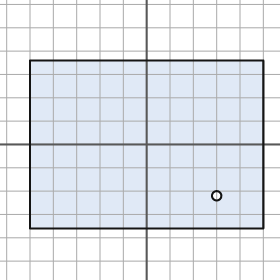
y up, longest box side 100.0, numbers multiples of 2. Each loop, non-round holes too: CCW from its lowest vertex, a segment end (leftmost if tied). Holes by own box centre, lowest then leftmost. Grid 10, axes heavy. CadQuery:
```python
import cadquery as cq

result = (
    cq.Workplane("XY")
    .moveTo(-50.0, -36.0)
    .lineTo(50.0, -36.0)
    .lineTo(50.0, 36.0)
    .lineTo(-50.0, 36.0)
    .close()
    .moveTo(30.0, -22.0)
    .circle(2.0)
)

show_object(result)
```